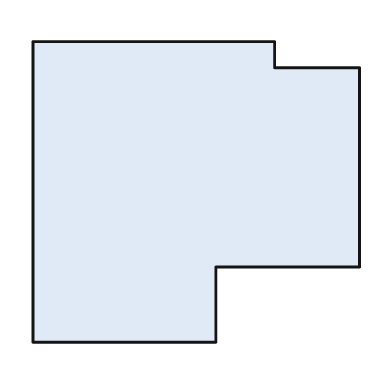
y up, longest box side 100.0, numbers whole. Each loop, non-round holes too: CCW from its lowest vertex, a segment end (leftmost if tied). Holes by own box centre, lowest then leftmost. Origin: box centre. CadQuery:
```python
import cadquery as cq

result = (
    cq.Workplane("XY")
    .moveTo(-50.0, -46.0)
    .lineTo(6.0, -46.0)
    .lineTo(6.0, -23.0)
    .lineTo(50.0, -23.0)
    .lineTo(50.0, 38.0)
    .lineTo(24.0, 38.0)
    .lineTo(24.0, 46.0)
    .lineTo(-50.0, 46.0)
    .close()
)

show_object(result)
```